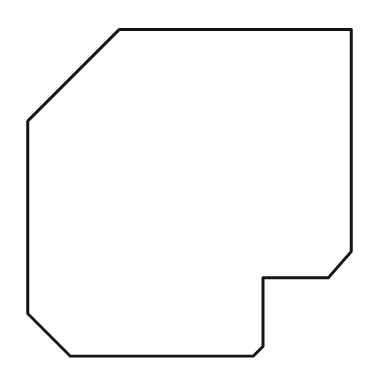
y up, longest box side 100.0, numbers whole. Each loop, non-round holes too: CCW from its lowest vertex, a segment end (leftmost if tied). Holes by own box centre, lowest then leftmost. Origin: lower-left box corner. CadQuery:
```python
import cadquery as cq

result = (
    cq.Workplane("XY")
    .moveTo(13.0, 0.0)
    .lineTo(69.0, 0.0)
    .lineTo(72.0, 3.0)
    .lineTo(72.0, 24.0)
    .lineTo(92.0, 24.0)
    .lineTo(99.0, 32.0)
    .lineTo(99.0, 100.0)
    .lineTo(28.0, 100.0)
    .lineTo(0.0, 72.0)
    .lineTo(0.0, 13.0)
    .close()
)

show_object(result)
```